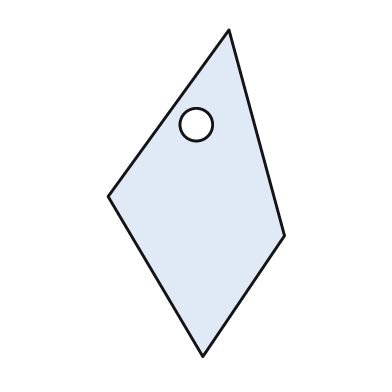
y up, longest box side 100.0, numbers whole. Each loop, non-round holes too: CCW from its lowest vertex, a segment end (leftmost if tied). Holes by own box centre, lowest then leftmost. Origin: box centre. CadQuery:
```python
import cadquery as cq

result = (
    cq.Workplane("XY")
    .moveTo(2.0, -50.0)
    .lineTo(27.0, -13.0)
    .lineTo(10.0, 50.0)
    .lineTo(-27.0, -1.0)
    .close()
    .moveTo(0.0, 21.0)
    .circle(5.0)
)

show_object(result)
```